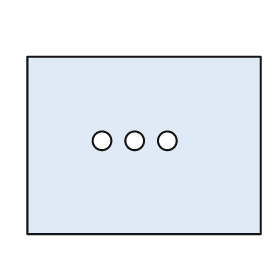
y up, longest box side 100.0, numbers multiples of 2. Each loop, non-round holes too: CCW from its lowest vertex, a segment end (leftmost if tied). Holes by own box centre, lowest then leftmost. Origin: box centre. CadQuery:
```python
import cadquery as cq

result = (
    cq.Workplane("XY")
    .moveTo(-50.0, -38.0)
    .lineTo(50.0, -38.0)
    .lineTo(50.0, 38.0)
    .lineTo(-50.0, 38.0)
    .close()
    .moveTo(-18.0, 2.0)
    .circle(4.0)
    .moveTo(-4.0, 2.0)
    .circle(4.0)
    .moveTo(10.0, 2.0)
    .circle(4.0)
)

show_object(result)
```